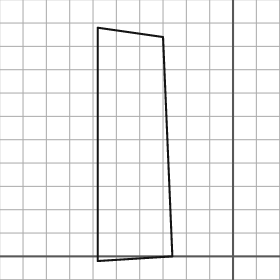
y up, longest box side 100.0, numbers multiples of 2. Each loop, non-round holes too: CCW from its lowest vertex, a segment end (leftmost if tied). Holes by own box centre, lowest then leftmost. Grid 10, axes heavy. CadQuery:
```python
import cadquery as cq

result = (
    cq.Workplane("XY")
    .moveTo(-58.0, -2.0)
    .lineTo(-26.0, 0.0)
    .lineTo(-30.0, 94.0)
    .lineTo(-58.0, 98.0)
    .close()
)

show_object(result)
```